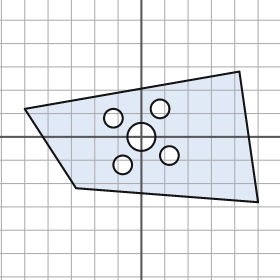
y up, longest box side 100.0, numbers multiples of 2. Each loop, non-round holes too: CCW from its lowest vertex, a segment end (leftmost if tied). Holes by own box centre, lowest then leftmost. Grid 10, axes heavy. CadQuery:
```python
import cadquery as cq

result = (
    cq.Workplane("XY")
    .moveTo(50.0, -28.0)
    .lineTo(42.0, 28.0)
    .lineTo(-50.0, 12.0)
    .lineTo(-28.0, -22.0)
    .close()
    .moveTo(-8.0, -12.0)
    .circle(4.0)
    .moveTo(12.0, -8.0)
    .circle(4.0)
    .moveTo(0.0, 0.0)
    .circle(6.0)
    .moveTo(-12.0, 8.0)
    .circle(4.0)
    .moveTo(8.0, 12.0)
    .circle(4.0)
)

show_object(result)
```